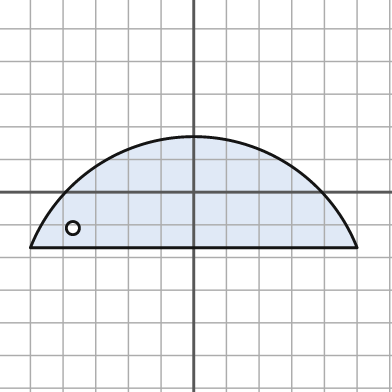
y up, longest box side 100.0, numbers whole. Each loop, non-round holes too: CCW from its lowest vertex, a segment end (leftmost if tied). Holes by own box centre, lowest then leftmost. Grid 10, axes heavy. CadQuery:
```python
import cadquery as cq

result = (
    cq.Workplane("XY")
    .moveTo(-50.0, -17.0)
    .lineTo(50.0, -17.0)
    .threePointArc((0.0, 17.0), (-50.0, -17.0))
    .close()
    .moveTo(-37.0, -11.0)
    .circle(2.0)
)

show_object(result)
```